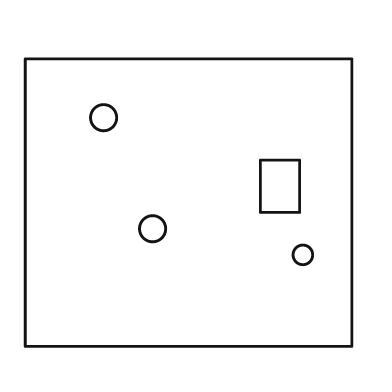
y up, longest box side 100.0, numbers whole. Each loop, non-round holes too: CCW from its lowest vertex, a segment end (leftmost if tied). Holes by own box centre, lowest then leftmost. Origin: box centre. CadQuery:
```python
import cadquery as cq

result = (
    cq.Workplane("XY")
    .moveTo(-50.0, -44.0)
    .lineTo(50.0, -44.0)
    .lineTo(50.0, 44.0)
    .lineTo(-50.0, 44.0)
    .close()
    .moveTo(35.0, -16.0)
    .circle(3.0)
    .moveTo(-11.0, -8.0)
    .circle(4.0)
    .moveTo(22.0, -3.0)
    .lineTo(34.0, -3.0)
    .lineTo(34.0, 13.0)
    .lineTo(22.0, 13.0)
    .close()
    .moveTo(-26.0, 26.0)
    .circle(4.0)
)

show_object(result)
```